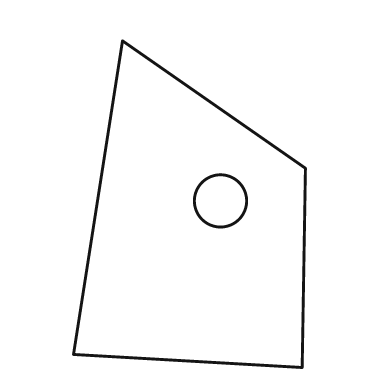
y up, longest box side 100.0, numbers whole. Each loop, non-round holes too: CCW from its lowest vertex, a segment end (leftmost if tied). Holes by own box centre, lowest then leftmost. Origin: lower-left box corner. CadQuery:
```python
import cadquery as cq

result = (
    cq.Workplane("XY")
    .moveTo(70.0, 0.0)
    .lineTo(71.0, 61.0)
    .lineTo(15.0, 100.0)
    .lineTo(0.0, 4.0)
    .close()
    .moveTo(45.0, 51.0)
    .circle(8.0)
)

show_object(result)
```